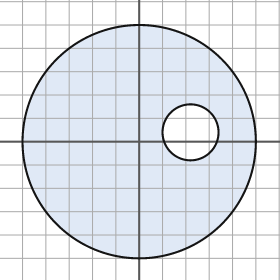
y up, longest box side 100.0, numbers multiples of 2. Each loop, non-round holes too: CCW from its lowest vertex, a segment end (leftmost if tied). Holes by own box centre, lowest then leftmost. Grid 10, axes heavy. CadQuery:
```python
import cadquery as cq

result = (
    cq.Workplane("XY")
    .moveTo(0.0, 0.0)
    .circle(50.0)
    .moveTo(22.0, 4.0)
    .circle(12.0)
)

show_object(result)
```